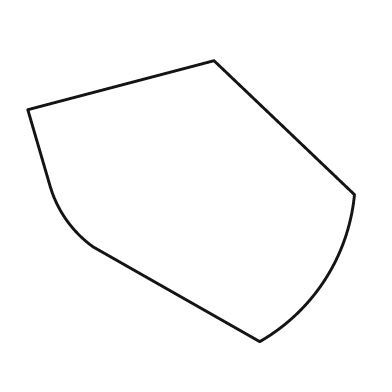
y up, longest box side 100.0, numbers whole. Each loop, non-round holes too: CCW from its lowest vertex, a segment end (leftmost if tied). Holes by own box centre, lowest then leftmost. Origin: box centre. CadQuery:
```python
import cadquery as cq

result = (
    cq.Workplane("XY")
    .moveTo(21.0, -43.0)
    .threePointArc((41.0, -24.0), (50.0, 2.0))
    .lineTo(7.0, 43.0)
    .lineTo(-50.0, 28.0)
    .lineTo(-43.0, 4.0)
    .threePointArc((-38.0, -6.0), (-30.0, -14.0))
    .close()
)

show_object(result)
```